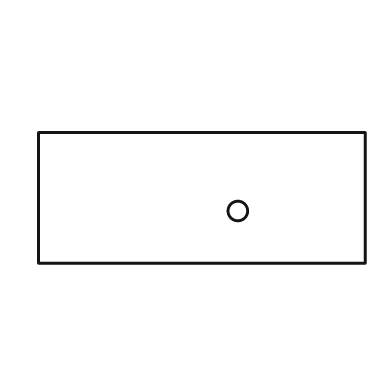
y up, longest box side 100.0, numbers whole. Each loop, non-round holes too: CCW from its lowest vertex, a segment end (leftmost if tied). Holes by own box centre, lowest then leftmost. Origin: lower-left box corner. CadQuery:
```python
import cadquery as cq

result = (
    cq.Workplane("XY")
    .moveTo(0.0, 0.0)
    .lineTo(100.0, 0.0)
    .lineTo(100.0, 40.0)
    .lineTo(0.0, 40.0)
    .close()
    .moveTo(61.0, 16.0)
    .circle(3.0)
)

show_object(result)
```